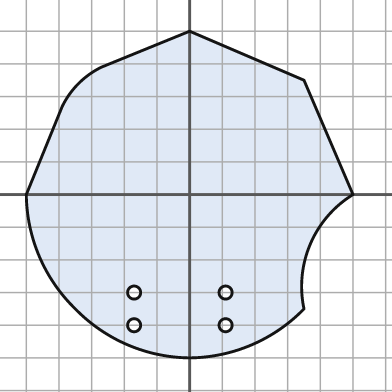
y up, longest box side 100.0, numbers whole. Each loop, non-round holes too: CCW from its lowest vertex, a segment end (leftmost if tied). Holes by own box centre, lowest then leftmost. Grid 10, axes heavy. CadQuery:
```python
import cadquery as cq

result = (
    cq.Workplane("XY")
    .moveTo(0.0, -50.0)
    .threePointArc((19.0, -46.0), (35.0, -35.0))
    .threePointArc((37.0, -15.0), (50.0, 0.0))
    .lineTo(35.0, 35.0)
    .lineTo(0.0, 50.0)
    .lineTo(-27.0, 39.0)
    .threePointArc((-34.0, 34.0), (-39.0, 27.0))
    .lineTo(-50.0, 0.0)
    .threePointArc((-46.0, -19.0), (-35.0, -35.0))
    .threePointArc((-19.0, -46.0), (0.0, -50.0))
    .close()
    .moveTo(-17.0, -40.0)
    .circle(2.0)
    .moveTo(11.0, -40.0)
    .circle(2.0)
    .moveTo(-17.0, -30.0)
    .circle(2.0)
    .moveTo(11.0, -30.0)
    .circle(2.0)
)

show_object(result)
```